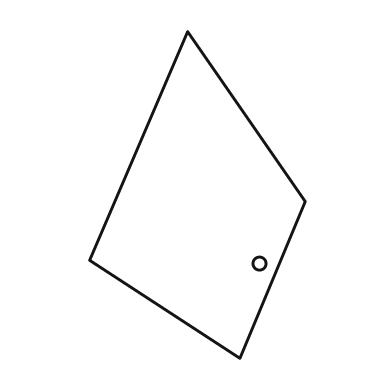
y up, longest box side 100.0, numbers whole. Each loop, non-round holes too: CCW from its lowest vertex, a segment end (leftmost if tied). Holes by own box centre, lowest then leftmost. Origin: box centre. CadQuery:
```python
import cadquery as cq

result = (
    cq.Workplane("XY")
    .moveTo(13.0, -50.0)
    .lineTo(33.0, -2.0)
    .lineTo(-3.0, 50.0)
    .lineTo(-33.0, -20.0)
    .close()
    .moveTo(19.0, -21.0)
    .circle(2.0)
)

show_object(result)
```